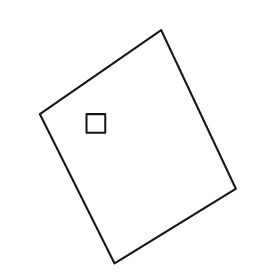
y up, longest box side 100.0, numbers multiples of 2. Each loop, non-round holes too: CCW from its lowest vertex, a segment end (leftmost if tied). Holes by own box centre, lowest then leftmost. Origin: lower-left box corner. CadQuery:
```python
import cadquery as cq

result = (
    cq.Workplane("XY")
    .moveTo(32.0, 0.0)
    .lineTo(84.0, 32.0)
    .lineTo(52.0, 100.0)
    .lineTo(0.0, 64.0)
    .close()
    .moveTo(20.0, 56.0)
    .lineTo(28.0, 56.0)
    .lineTo(28.0, 64.0)
    .lineTo(20.0, 64.0)
    .close()
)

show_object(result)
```